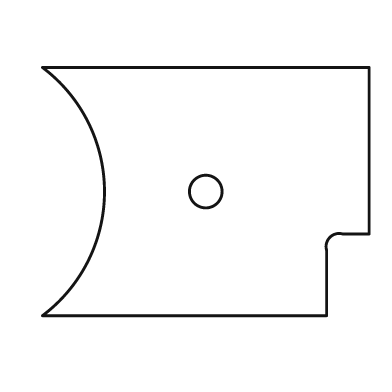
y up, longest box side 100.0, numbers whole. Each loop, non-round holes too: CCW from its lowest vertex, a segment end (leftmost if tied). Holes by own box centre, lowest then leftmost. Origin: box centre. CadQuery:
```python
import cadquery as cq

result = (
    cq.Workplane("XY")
    .moveTo(-50.0, -38.0)
    .lineTo(37.0, -38.0)
    .lineTo(37.0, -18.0)
    .threePointArc((38.0, -14.0), (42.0, -13.0))
    .lineTo(50.0, -13.0)
    .lineTo(50.0, 38.0)
    .lineTo(-50.0, 38.0)
    .threePointArc((-31.0, 0.0), (-50.0, -38.0))
    .close()
    .moveTo(0.0, 0.0)
    .circle(5.0)
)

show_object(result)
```